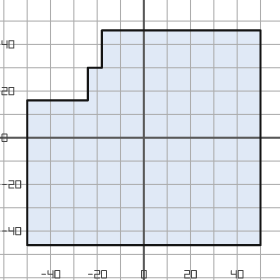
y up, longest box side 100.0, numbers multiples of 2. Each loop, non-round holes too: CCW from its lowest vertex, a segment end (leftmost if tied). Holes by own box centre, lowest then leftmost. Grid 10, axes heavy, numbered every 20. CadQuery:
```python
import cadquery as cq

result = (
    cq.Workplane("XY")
    .moveTo(-50.0, -46.0)
    .lineTo(50.0, -46.0)
    .lineTo(50.0, 46.0)
    .lineTo(-18.0, 46.0)
    .lineTo(-18.0, 30.0)
    .lineTo(-24.0, 30.0)
    .lineTo(-24.0, 16.0)
    .lineTo(-50.0, 16.0)
    .close()
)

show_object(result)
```